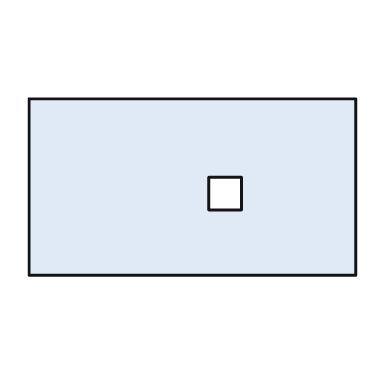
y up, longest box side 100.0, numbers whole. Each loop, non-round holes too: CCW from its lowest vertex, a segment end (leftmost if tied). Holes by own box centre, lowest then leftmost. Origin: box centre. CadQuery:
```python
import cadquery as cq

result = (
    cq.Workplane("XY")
    .moveTo(-50.0, -27.0)
    .lineTo(50.0, -27.0)
    .lineTo(50.0, 27.0)
    .lineTo(-50.0, 27.0)
    .close()
    .moveTo(5.0, -7.0)
    .lineTo(15.0, -7.0)
    .lineTo(15.0, 3.0)
    .lineTo(5.0, 3.0)
    .close()
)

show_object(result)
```